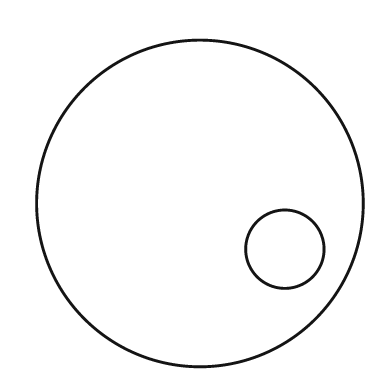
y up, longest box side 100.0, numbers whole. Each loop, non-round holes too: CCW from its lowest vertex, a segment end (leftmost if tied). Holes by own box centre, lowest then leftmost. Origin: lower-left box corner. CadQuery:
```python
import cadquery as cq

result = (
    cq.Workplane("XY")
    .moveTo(50.0, 50.0)
    .circle(50.0)
    .moveTo(76.0, 36.0)
    .circle(12.0)
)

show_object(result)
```